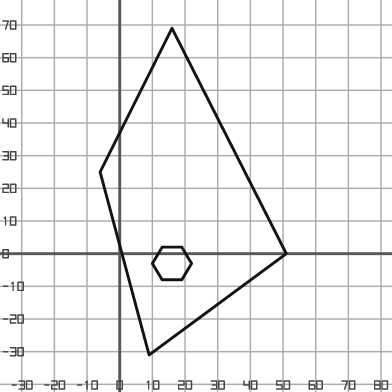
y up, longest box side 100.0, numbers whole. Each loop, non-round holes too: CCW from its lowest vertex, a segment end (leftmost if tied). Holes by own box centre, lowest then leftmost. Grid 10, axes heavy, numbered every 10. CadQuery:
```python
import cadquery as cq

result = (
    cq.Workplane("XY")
    .moveTo(9.0, -31.0)
    .lineTo(51.0, 0.0)
    .lineTo(16.0, 69.0)
    .lineTo(-6.0, 25.0)
    .close()
    .moveTo(13.0, -8.0)
    .lineTo(19.0, -8.0)
    .lineTo(22.0, -3.0)
    .lineTo(19.0, 2.0)
    .lineTo(13.0, 2.0)
    .lineTo(10.0, -3.0)
    .close()
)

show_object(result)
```